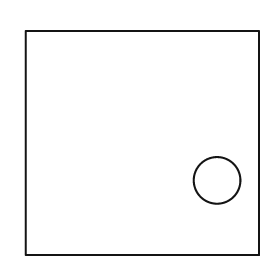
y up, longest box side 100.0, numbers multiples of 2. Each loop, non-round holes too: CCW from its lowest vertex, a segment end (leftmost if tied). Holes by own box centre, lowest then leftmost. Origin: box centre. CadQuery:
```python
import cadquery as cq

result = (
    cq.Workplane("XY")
    .moveTo(-50.0, -48.0)
    .lineTo(50.0, -48.0)
    .lineTo(50.0, 48.0)
    .lineTo(-50.0, 48.0)
    .close()
    .moveTo(32.0, -16.0)
    .circle(10.0)
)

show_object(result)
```